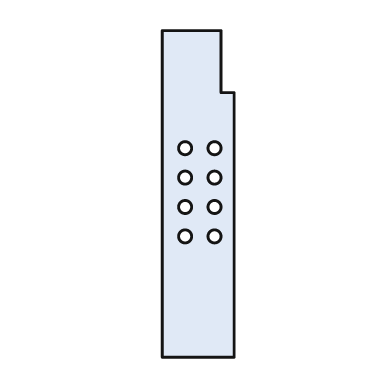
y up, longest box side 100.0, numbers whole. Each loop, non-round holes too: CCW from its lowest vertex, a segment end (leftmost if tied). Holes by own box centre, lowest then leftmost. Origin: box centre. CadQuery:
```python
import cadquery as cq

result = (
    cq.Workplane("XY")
    .moveTo(-11.0, -50.0)
    .lineTo(11.0, -50.0)
    .lineTo(11.0, 31.0)
    .lineTo(7.0, 31.0)
    .lineTo(7.0, 50.0)
    .lineTo(-11.0, 50.0)
    .close()
    .moveTo(-4.0, -13.0)
    .circle(2.0)
    .moveTo(5.0, -13.0)
    .circle(2.0)
    .moveTo(-4.0, -4.0)
    .circle(2.0)
    .moveTo(5.0, -4.0)
    .circle(2.0)
    .moveTo(-4.0, 5.0)
    .circle(2.0)
    .moveTo(5.0, 5.0)
    .circle(2.0)
    .moveTo(-4.0, 14.0)
    .circle(2.0)
    .moveTo(5.0, 14.0)
    .circle(2.0)
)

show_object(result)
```